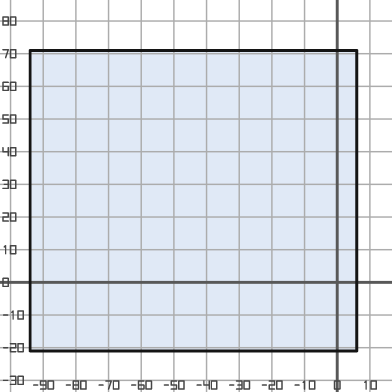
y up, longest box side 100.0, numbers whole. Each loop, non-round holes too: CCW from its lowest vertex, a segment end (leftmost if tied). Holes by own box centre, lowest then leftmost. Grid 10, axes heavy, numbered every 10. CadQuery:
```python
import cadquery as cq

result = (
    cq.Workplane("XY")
    .moveTo(-94.0, -21.0)
    .lineTo(6.0, -21.0)
    .lineTo(6.0, 71.0)
    .lineTo(-94.0, 71.0)
    .close()
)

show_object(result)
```